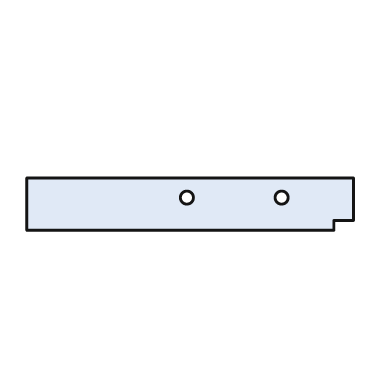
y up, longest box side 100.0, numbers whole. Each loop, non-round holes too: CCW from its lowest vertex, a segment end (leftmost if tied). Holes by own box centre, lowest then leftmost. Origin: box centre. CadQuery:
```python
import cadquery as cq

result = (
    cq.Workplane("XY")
    .moveTo(-50.0, -8.0)
    .lineTo(44.0, -8.0)
    .lineTo(44.0, -5.0)
    .lineTo(50.0, -5.0)
    .lineTo(50.0, 8.0)
    .lineTo(-50.0, 8.0)
    .close()
    .moveTo(-1.0, 2.0)
    .circle(2.0)
    .moveTo(28.0, 2.0)
    .circle(2.0)
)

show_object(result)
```